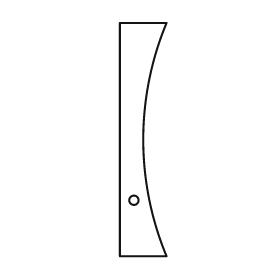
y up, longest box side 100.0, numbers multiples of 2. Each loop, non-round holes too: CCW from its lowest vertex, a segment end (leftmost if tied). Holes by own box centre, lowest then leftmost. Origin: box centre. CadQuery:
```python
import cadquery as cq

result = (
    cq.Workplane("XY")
    .moveTo(-10.0, -50.0)
    .lineTo(10.0, -50.0)
    .threePointArc((0.0, 0.0), (10.0, 50.0))
    .lineTo(-10.0, 50.0)
    .close()
    .moveTo(-4.0, -26.0)
    .circle(2.0)
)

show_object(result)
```